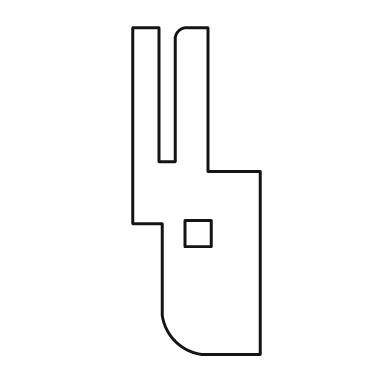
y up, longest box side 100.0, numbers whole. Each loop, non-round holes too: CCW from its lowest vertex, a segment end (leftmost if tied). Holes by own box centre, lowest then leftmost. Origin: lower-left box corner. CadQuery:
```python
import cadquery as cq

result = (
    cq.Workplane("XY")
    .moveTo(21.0, 0.0)
    .lineTo(39.0, 0.0)
    .lineTo(39.0, 56.0)
    .lineTo(23.0, 56.0)
    .lineTo(23.0, 100.0)
    .lineTo(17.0, 100.0)
    .threePointArc((14.0, 99.0), (13.0, 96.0))
    .lineTo(13.0, 59.0)
    .lineTo(8.0, 59.0)
    .lineTo(8.0, 100.0)
    .lineTo(0.0, 100.0)
    .lineTo(0.0, 40.0)
    .lineTo(9.0, 40.0)
    .lineTo(9.0, 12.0)
    .threePointArc((13.0, 4.0), (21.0, 0.0))
    .close()
    .moveTo(16.0, 33.0)
    .lineTo(24.0, 33.0)
    .lineTo(24.0, 41.0)
    .lineTo(16.0, 41.0)
    .close()
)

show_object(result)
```